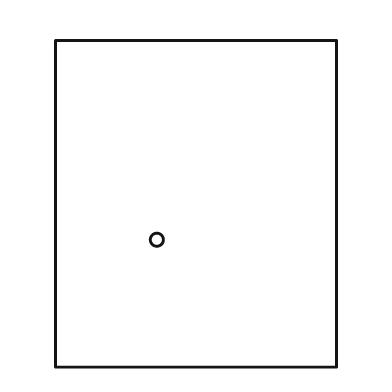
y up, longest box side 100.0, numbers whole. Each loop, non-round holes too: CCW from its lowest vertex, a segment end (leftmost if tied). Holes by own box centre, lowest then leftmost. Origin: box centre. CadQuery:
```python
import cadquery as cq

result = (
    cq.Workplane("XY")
    .moveTo(-43.0, -50.0)
    .lineTo(43.0, -50.0)
    .lineTo(43.0, 50.0)
    .lineTo(-43.0, 50.0)
    .close()
    .moveTo(-12.0, -11.0)
    .circle(2.0)
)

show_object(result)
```